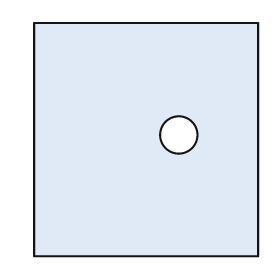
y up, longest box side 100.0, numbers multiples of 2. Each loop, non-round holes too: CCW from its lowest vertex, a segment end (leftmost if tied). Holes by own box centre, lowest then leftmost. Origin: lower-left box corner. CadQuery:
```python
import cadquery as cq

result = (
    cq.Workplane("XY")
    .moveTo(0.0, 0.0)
    .lineTo(96.0, 0.0)
    .lineTo(96.0, 100.0)
    .lineTo(0.0, 100.0)
    .close()
    .moveTo(62.0, 52.0)
    .circle(8.0)
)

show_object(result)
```